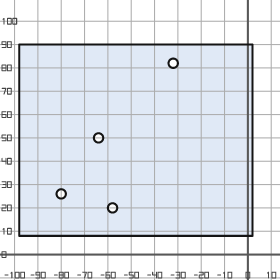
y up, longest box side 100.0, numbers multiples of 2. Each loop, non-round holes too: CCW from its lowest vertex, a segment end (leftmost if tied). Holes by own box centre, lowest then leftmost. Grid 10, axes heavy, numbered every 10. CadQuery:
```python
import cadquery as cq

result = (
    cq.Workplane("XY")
    .moveTo(-98.0, 8.0)
    .lineTo(2.0, 8.0)
    .lineTo(2.0, 90.0)
    .lineTo(-98.0, 90.0)
    .close()
    .moveTo(-58.0, 20.0)
    .circle(2.0)
    .moveTo(-80.0, 26.0)
    .circle(2.0)
    .moveTo(-64.0, 50.0)
    .circle(2.0)
    .moveTo(-32.0, 82.0)
    .circle(2.0)
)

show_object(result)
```